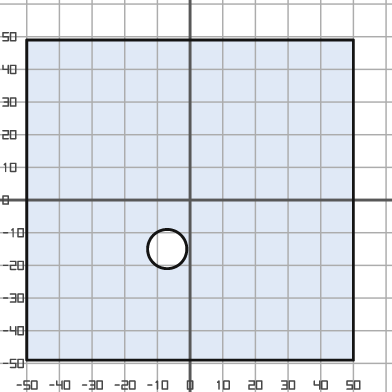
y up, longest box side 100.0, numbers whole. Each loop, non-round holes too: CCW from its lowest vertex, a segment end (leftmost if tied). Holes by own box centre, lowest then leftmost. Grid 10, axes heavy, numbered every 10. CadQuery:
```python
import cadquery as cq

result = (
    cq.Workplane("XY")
    .moveTo(-50.0, -49.0)
    .lineTo(50.0, -49.0)
    .lineTo(50.0, 49.0)
    .lineTo(-50.0, 49.0)
    .close()
    .moveTo(-7.0, -15.0)
    .circle(6.0)
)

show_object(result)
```